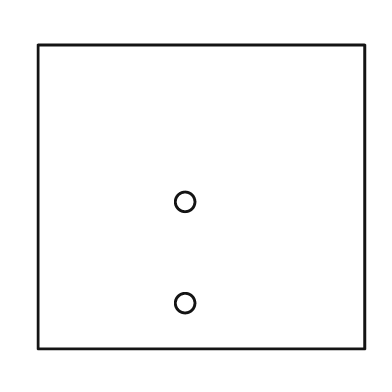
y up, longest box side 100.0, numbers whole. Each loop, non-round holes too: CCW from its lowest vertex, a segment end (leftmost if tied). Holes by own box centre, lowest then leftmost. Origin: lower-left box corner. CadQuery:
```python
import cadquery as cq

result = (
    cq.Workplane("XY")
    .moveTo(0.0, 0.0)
    .lineTo(100.0, 0.0)
    .lineTo(100.0, 93.0)
    .lineTo(0.0, 93.0)
    .close()
    .moveTo(45.0, 14.0)
    .circle(3.0)
    .moveTo(45.0, 45.0)
    .circle(3.0)
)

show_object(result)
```